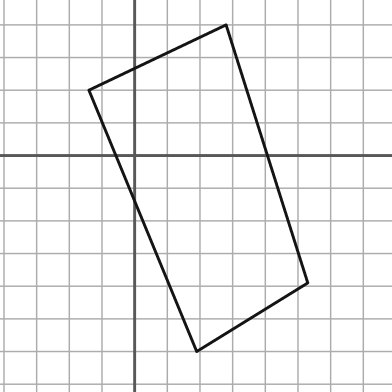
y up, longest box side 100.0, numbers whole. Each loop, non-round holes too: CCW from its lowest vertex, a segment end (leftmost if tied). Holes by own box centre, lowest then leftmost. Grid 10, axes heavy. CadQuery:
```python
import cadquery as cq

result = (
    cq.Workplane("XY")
    .moveTo(19.0, -60.0)
    .lineTo(53.0, -39.0)
    .lineTo(28.0, 40.0)
    .lineTo(-14.0, 20.0)
    .close()
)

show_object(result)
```